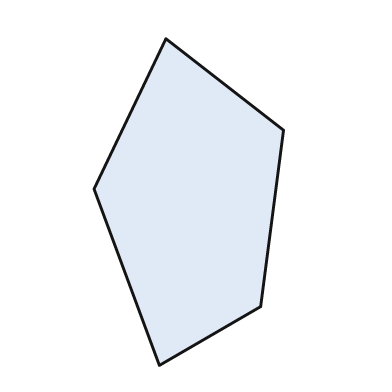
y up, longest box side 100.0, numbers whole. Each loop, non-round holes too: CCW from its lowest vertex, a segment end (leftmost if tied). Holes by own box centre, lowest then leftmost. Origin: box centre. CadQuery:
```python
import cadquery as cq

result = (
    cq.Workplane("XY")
    .moveTo(-9.0, -50.0)
    .lineTo(22.0, -32.0)
    .lineTo(29.0, 22.0)
    .lineTo(-7.0, 50.0)
    .lineTo(-29.0, 4.0)
    .close()
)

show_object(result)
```